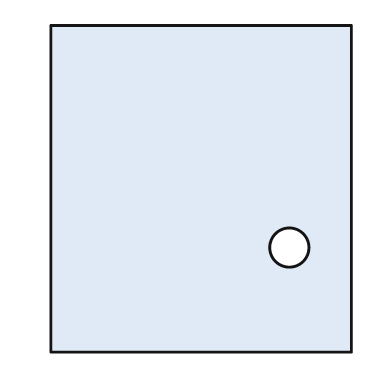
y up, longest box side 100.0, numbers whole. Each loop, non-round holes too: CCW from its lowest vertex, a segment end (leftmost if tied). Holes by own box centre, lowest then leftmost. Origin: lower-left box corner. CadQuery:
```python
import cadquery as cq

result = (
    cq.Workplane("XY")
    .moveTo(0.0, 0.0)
    .lineTo(92.0, 0.0)
    .lineTo(92.0, 100.0)
    .lineTo(0.0, 100.0)
    .close()
    .moveTo(73.0, 32.0)
    .circle(6.0)
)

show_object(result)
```